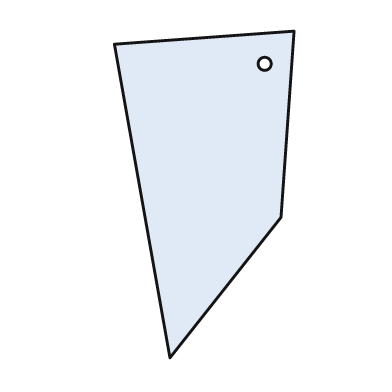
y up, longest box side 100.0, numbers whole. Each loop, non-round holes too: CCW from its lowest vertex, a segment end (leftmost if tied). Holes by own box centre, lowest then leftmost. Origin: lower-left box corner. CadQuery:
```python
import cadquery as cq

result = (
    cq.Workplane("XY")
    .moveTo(17.0, 0.0)
    .lineTo(51.0, 43.0)
    .lineTo(55.0, 100.0)
    .lineTo(0.0, 96.0)
    .close()
    .moveTo(46.0, 90.0)
    .circle(2.0)
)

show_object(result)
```